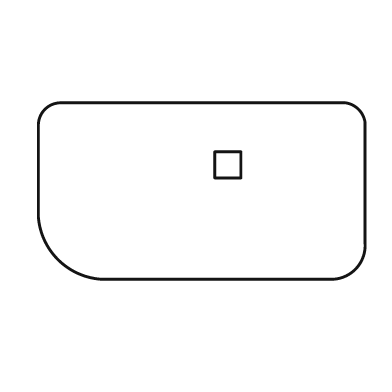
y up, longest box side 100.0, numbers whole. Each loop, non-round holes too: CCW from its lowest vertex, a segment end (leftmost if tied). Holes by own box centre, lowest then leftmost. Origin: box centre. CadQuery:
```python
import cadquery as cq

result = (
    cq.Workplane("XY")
    .moveTo(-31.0, -27.0)
    .lineTo(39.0, -27.0)
    .threePointArc((47.0, -24.0), (50.0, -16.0))
    .lineTo(50.0, 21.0)
    .threePointArc((48.0, 25.0), (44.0, 27.0))
    .lineTo(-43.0, 27.0)
    .threePointArc((-48.0, 25.0), (-50.0, 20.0))
    .lineTo(-50.0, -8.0)
    .threePointArc((-44.0, -21.0), (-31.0, -27.0))
    .close()
    .moveTo(4.0, 4.0)
    .lineTo(12.0, 4.0)
    .lineTo(12.0, 12.0)
    .lineTo(4.0, 12.0)
    .close()
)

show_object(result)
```